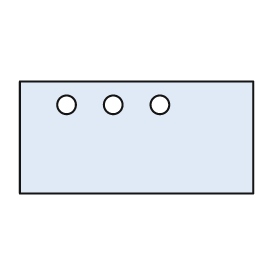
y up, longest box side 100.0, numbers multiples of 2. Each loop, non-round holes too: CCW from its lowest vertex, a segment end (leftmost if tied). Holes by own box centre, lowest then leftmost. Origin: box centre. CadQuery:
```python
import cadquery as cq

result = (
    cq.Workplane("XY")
    .moveTo(-50.0, -24.0)
    .lineTo(50.0, -24.0)
    .lineTo(50.0, 24.0)
    .lineTo(-50.0, 24.0)
    .close()
    .moveTo(-30.0, 14.0)
    .circle(4.0)
    .moveTo(-10.0, 14.0)
    .circle(4.0)
    .moveTo(10.0, 14.0)
    .circle(4.0)
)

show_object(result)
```